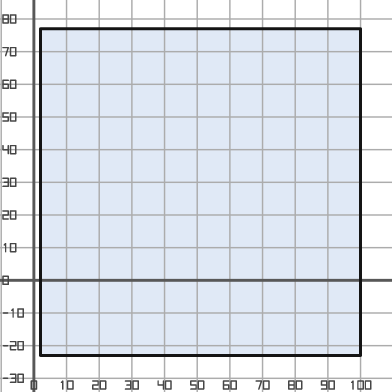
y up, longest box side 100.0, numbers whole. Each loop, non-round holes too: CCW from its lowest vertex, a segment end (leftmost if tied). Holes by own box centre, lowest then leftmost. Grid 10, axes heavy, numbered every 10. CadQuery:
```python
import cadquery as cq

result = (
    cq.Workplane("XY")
    .moveTo(2.0, -23.0)
    .lineTo(100.0, -23.0)
    .lineTo(100.0, 77.0)
    .lineTo(2.0, 77.0)
    .close()
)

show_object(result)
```